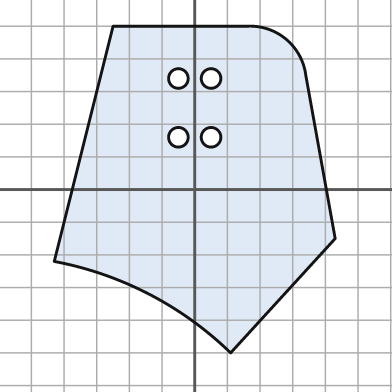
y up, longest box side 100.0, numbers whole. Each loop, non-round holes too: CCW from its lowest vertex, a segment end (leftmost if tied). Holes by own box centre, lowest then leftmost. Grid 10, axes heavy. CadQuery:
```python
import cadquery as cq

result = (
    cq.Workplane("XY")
    .moveTo(11.0, -50.0)
    .lineTo(43.0, -15.0)
    .lineTo(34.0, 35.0)
    .threePointArc((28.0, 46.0), (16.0, 50.0))
    .lineTo(-25.0, 50.0)
    .lineTo(-43.0, -22.0)
    .threePointArc((-14.0, -32.0), (11.0, -50.0))
    .close()
    .moveTo(-5.0, 16.0)
    .circle(3.0)
    .moveTo(5.0, 16.0)
    .circle(3.0)
    .moveTo(-5.0, 34.0)
    .circle(3.0)
    .moveTo(5.0, 34.0)
    .circle(3.0)
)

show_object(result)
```